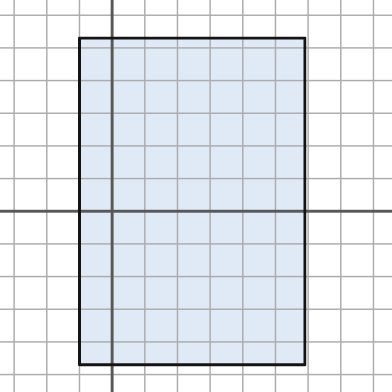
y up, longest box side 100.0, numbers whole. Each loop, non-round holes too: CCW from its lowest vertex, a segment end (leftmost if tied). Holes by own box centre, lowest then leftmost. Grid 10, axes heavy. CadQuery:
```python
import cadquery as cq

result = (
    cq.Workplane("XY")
    .moveTo(-10.0, -47.0)
    .lineTo(59.0, -47.0)
    .lineTo(59.0, 53.0)
    .lineTo(-10.0, 53.0)
    .close()
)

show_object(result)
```